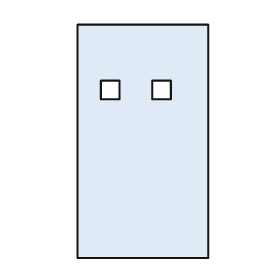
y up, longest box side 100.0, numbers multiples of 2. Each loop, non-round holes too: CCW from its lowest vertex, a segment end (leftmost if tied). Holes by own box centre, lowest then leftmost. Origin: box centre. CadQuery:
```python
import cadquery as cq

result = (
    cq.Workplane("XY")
    .moveTo(-28.0, -50.0)
    .lineTo(28.0, -50.0)
    .lineTo(28.0, 50.0)
    .lineTo(-28.0, 50.0)
    .close()
    .moveTo(-18.0, 18.0)
    .lineTo(-10.0, 18.0)
    .lineTo(-10.0, 26.0)
    .lineTo(-18.0, 26.0)
    .close()
    .moveTo(4.0, 18.0)
    .lineTo(12.0, 18.0)
    .lineTo(12.0, 26.0)
    .lineTo(4.0, 26.0)
    .close()
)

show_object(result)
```